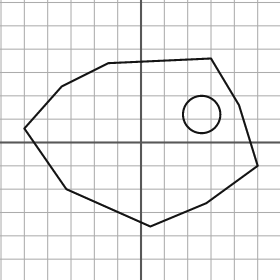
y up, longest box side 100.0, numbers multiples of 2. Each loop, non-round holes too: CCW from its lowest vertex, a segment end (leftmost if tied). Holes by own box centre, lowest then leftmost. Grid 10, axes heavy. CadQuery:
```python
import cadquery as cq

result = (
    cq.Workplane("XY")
    .moveTo(4.0, -36.0)
    .lineTo(28.0, -26.0)
    .lineTo(50.0, -10.0)
    .lineTo(42.0, 16.0)
    .lineTo(30.0, 36.0)
    .lineTo(-14.0, 34.0)
    .lineTo(-34.0, 24.0)
    .lineTo(-50.0, 6.0)
    .lineTo(-32.0, -20.0)
    .close()
    .moveTo(26.0, 12.0)
    .circle(8.0)
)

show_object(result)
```